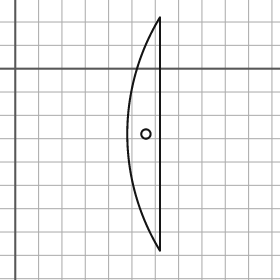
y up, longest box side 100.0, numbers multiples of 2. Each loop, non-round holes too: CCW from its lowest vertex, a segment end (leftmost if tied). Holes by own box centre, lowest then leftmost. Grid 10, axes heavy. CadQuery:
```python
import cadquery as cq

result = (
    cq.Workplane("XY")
    .moveTo(62.0, -78.0)
    .lineTo(62.0, 22.0)
    .threePointArc((48.0, -28.0), (62.0, -78.0))
    .close()
    .moveTo(56.0, -28.0)
    .circle(2.0)
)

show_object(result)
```